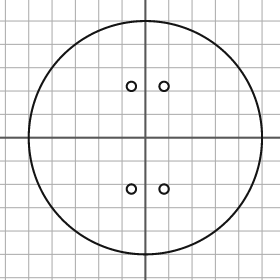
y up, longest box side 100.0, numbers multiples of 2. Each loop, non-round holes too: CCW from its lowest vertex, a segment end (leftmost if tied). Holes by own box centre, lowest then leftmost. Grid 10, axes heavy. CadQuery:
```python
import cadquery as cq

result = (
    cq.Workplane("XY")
    .moveTo(0.0, 0.0)
    .circle(50.0)
    .moveTo(-6.0, -22.0)
    .circle(2.0)
    .moveTo(8.0, -22.0)
    .circle(2.0)
    .moveTo(-6.0, 22.0)
    .circle(2.0)
    .moveTo(8.0, 22.0)
    .circle(2.0)
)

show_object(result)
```